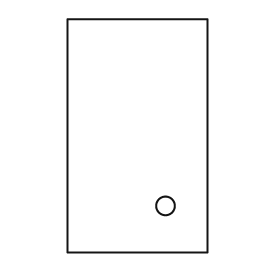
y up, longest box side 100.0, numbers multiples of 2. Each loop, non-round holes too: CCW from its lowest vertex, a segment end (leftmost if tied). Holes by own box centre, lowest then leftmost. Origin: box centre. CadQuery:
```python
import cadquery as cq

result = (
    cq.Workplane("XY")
    .moveTo(-30.0, -50.0)
    .lineTo(30.0, -50.0)
    .lineTo(30.0, 50.0)
    .lineTo(-30.0, 50.0)
    .close()
    .moveTo(12.0, -30.0)
    .circle(4.0)
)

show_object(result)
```